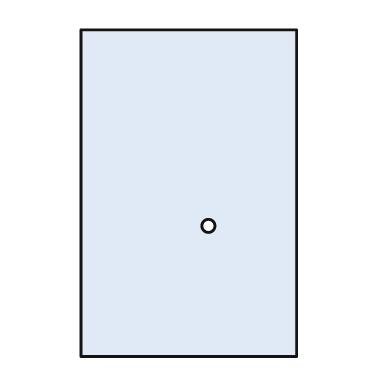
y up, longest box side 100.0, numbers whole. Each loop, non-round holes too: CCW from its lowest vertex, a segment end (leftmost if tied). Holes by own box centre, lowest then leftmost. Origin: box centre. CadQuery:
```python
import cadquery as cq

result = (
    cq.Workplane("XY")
    .moveTo(-33.0, -50.0)
    .lineTo(33.0, -50.0)
    .lineTo(33.0, 50.0)
    .lineTo(-33.0, 50.0)
    .close()
    .moveTo(6.0, -10.0)
    .circle(2.0)
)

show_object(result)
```